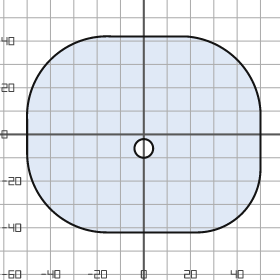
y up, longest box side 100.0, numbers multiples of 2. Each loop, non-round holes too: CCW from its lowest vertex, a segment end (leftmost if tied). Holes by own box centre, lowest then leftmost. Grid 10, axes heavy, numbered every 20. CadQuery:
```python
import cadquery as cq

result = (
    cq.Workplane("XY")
    .moveTo(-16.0, -42.0)
    .lineTo(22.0, -42.0)
    .threePointArc((42.0, -34.0), (50.0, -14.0))
    .lineTo(50.0, 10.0)
    .threePointArc((40.0, 32.0), (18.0, 42.0))
    .lineTo(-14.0, 42.0)
    .threePointArc((-40.0, 32.0), (-50.0, 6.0))
    .lineTo(-50.0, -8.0)
    .threePointArc((-40.0, -32.0), (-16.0, -42.0))
    .close()
    .moveTo(0.0, -6.0)
    .circle(4.0)
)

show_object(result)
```